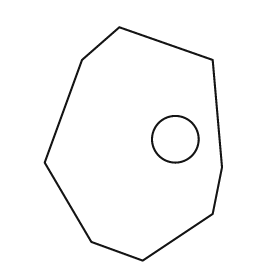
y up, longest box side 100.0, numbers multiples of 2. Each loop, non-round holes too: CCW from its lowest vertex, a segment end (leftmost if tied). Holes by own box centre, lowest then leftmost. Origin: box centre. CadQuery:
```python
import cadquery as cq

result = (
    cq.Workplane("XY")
    .moveTo(4.0, -50.0)
    .lineTo(34.0, -30.0)
    .lineTo(38.0, -10.0)
    .lineTo(34.0, 36.0)
    .lineTo(-6.0, 50.0)
    .lineTo(-22.0, 36.0)
    .lineTo(-38.0, -8.0)
    .lineTo(-18.0, -42.0)
    .close()
    .moveTo(18.0, 2.0)
    .circle(10.0)
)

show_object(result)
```